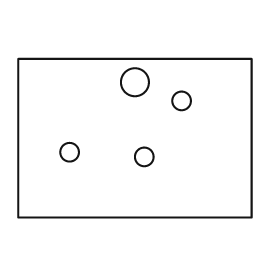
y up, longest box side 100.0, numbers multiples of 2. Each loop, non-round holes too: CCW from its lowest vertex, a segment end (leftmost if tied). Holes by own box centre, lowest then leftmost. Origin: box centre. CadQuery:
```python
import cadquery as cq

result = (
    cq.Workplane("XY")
    .moveTo(-50.0, -34.0)
    .lineTo(50.0, -34.0)
    .lineTo(50.0, 34.0)
    .lineTo(-50.0, 34.0)
    .close()
    .moveTo(4.0, -8.0)
    .circle(4.0)
    .moveTo(-28.0, -6.0)
    .circle(4.0)
    .moveTo(20.0, 16.0)
    .circle(4.0)
    .moveTo(0.0, 24.0)
    .circle(6.0)
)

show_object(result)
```